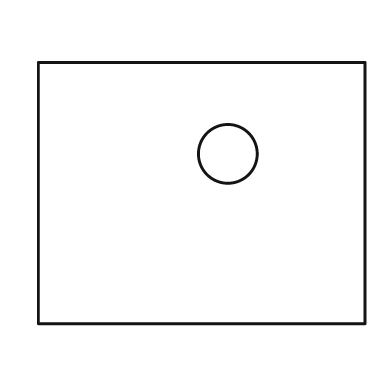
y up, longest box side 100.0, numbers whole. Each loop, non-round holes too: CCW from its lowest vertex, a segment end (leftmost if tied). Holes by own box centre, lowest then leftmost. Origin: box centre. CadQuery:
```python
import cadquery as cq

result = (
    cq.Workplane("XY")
    .moveTo(-50.0, -40.0)
    .lineTo(50.0, -40.0)
    .lineTo(50.0, 40.0)
    .lineTo(-50.0, 40.0)
    .close()
    .moveTo(8.0, 12.0)
    .circle(9.0)
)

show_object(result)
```